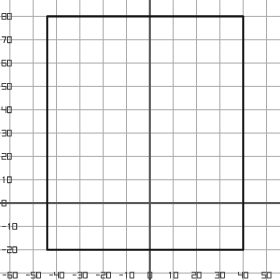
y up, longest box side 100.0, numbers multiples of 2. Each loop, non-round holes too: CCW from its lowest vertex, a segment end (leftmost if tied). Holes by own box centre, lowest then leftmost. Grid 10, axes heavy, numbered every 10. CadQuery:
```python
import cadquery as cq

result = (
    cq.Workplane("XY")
    .moveTo(-44.0, -20.0)
    .lineTo(40.0, -20.0)
    .lineTo(40.0, 80.0)
    .lineTo(-44.0, 80.0)
    .close()
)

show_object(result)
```